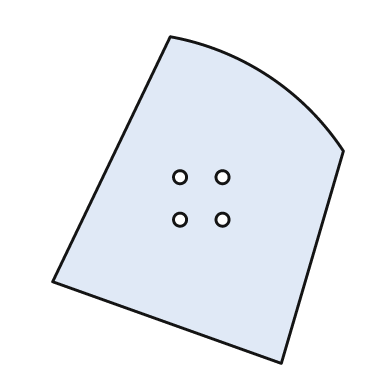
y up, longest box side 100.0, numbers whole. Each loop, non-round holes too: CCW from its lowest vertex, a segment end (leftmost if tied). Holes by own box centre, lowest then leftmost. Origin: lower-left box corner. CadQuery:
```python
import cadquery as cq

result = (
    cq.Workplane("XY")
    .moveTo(70.0, 0.0)
    .lineTo(89.0, 65.0)
    .threePointArc((66.0, 88.0), (36.0, 100.0))
    .lineTo(0.0, 25.0)
    .close()
    .moveTo(39.0, 44.0)
    .circle(2.0)
    .moveTo(52.0, 44.0)
    .circle(2.0)
    .moveTo(39.0, 57.0)
    .circle(2.0)
    .moveTo(52.0, 57.0)
    .circle(2.0)
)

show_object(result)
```